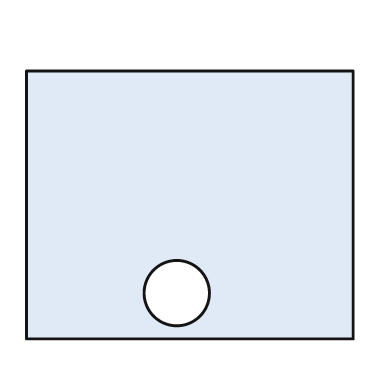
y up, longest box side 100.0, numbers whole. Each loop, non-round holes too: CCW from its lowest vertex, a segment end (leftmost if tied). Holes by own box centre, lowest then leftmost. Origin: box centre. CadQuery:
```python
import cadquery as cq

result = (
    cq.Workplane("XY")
    .moveTo(-50.0, -41.0)
    .lineTo(50.0, -41.0)
    .lineTo(50.0, 41.0)
    .lineTo(-50.0, 41.0)
    .close()
    .moveTo(-4.0, -27.0)
    .circle(10.0)
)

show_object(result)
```